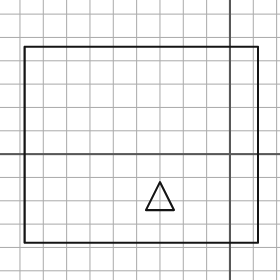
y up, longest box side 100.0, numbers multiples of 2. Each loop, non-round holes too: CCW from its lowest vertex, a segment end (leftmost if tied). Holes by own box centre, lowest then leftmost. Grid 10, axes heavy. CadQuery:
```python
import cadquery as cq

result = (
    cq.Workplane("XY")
    .moveTo(-88.0, -38.0)
    .lineTo(12.0, -38.0)
    .lineTo(12.0, 46.0)
    .lineTo(-88.0, 46.0)
    .close()
    .moveTo(-36.0, -24.0)
    .lineTo(-24.0, -24.0)
    .lineTo(-30.0, -12.0)
    .close()
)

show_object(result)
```